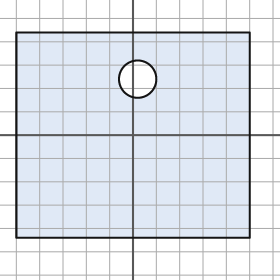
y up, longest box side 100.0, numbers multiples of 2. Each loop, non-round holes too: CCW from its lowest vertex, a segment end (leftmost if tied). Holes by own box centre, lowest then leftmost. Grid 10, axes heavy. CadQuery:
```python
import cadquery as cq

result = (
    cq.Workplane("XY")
    .moveTo(-50.0, -44.0)
    .lineTo(50.0, -44.0)
    .lineTo(50.0, 44.0)
    .lineTo(-50.0, 44.0)
    .close()
    .moveTo(2.0, 24.0)
    .circle(8.0)
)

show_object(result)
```